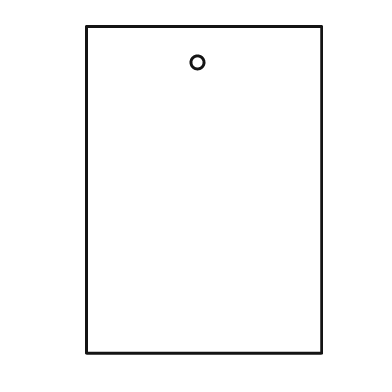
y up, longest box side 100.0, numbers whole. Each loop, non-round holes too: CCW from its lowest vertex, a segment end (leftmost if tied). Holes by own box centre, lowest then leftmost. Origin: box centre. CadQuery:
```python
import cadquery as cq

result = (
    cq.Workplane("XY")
    .moveTo(-36.0, -50.0)
    .lineTo(36.0, -50.0)
    .lineTo(36.0, 50.0)
    .lineTo(-36.0, 50.0)
    .close()
    .moveTo(-2.0, 39.0)
    .circle(2.0)
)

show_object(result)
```